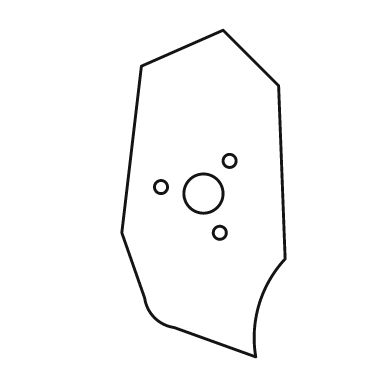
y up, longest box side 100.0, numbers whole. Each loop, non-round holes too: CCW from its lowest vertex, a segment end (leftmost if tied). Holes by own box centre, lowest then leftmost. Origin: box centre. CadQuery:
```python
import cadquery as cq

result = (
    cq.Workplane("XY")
    .moveTo(16.0, -50.0)
    .threePointArc((17.0, -34.0), (25.0, -20.0))
    .lineTo(23.0, 33.0)
    .lineTo(6.0, 50.0)
    .lineTo(-19.0, 39.0)
    .lineTo(-25.0, -12.0)
    .lineTo(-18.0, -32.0)
    .threePointArc((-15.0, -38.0), (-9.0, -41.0))
    .close()
    .moveTo(5.0, -12.0)
    .circle(2.0)
    .moveTo(0.0, 0.0)
    .circle(6.0)
    .moveTo(-13.0, 2.0)
    .circle(2.0)
    .moveTo(8.0, 10.0)
    .circle(2.0)
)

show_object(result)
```